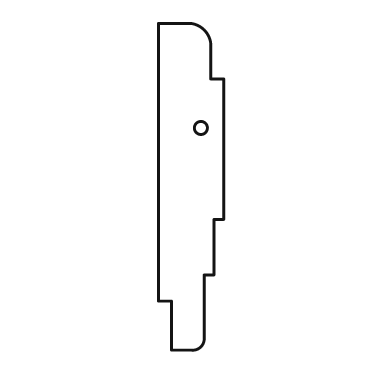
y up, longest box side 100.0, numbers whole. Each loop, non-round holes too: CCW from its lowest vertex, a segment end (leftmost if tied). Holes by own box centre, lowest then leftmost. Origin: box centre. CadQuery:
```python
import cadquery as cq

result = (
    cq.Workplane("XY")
    .moveTo(-6.0, -50.0)
    .lineTo(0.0, -50.0)
    .threePointArc((3.0, -49.0), (4.0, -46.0))
    .lineTo(4.0, -27.0)
    .lineTo(7.0, -27.0)
    .lineTo(7.0, -10.0)
    .lineTo(10.0, -10.0)
    .lineTo(10.0, 33.0)
    .lineTo(6.0, 33.0)
    .lineTo(6.0, 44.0)
    .threePointArc((4.0, 48.0), (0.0, 50.0))
    .lineTo(-10.0, 50.0)
    .lineTo(-10.0, -35.0)
    .lineTo(-6.0, -35.0)
    .close()
    .moveTo(3.0, 18.0)
    .circle(2.0)
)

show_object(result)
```